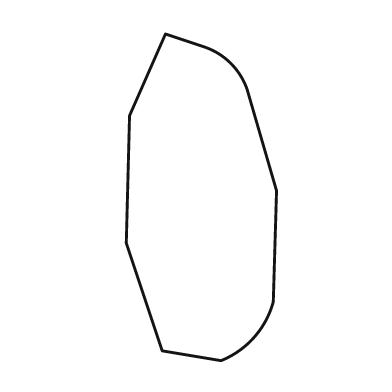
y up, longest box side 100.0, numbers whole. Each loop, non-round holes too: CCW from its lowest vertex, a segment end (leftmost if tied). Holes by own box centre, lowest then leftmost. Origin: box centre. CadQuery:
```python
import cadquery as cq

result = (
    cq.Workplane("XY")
    .moveTo(6.0, -50.0)
    .threePointArc((16.0, -43.0), (22.0, -32.0))
    .lineTo(23.0, 2.0)
    .lineTo(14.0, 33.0)
    .threePointArc((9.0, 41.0), (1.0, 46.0))
    .lineTo(-11.0, 50.0)
    .lineTo(-22.0, 25.0)
    .lineTo(-23.0, -14.0)
    .lineTo(-12.0, -47.0)
    .close()
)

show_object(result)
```